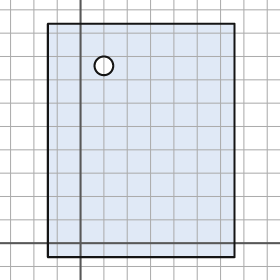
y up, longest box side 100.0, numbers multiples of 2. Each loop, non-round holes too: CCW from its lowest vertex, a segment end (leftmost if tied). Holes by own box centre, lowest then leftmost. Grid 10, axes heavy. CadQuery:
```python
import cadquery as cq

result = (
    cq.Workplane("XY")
    .moveTo(-14.0, -6.0)
    .lineTo(66.0, -6.0)
    .lineTo(66.0, 94.0)
    .lineTo(-14.0, 94.0)
    .close()
    .moveTo(10.0, 76.0)
    .circle(4.0)
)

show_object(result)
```